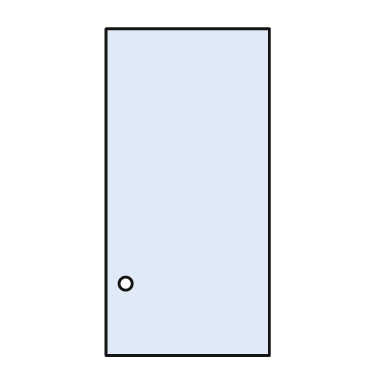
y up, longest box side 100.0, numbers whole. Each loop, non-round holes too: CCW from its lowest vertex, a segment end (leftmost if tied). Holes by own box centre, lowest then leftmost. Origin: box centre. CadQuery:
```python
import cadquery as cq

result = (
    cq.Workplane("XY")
    .moveTo(-25.0, -50.0)
    .lineTo(25.0, -50.0)
    .lineTo(25.0, 50.0)
    .lineTo(-25.0, 50.0)
    .close()
    .moveTo(-19.0, -28.0)
    .circle(2.0)
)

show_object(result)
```